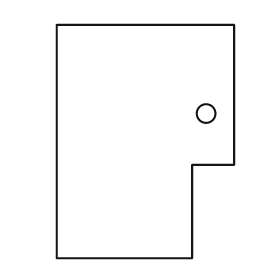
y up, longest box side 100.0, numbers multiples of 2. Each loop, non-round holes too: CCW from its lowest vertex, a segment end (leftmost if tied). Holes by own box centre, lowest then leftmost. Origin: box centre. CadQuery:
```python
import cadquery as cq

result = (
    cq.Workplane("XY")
    .moveTo(-38.0, -50.0)
    .lineTo(20.0, -50.0)
    .lineTo(20.0, -10.0)
    .lineTo(38.0, -10.0)
    .lineTo(38.0, 50.0)
    .lineTo(-38.0, 50.0)
    .close()
    .moveTo(26.0, 12.0)
    .circle(4.0)
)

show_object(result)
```